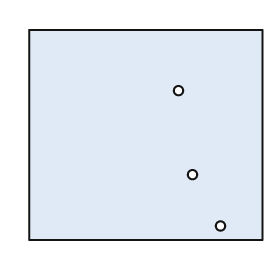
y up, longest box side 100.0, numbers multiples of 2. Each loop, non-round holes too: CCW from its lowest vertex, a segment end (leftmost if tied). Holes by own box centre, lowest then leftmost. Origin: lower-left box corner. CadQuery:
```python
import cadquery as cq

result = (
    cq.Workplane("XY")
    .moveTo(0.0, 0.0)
    .lineTo(100.0, 0.0)
    .lineTo(100.0, 90.0)
    .lineTo(0.0, 90.0)
    .close()
    .moveTo(82.0, 6.0)
    .circle(2.0)
    .moveTo(70.0, 28.0)
    .circle(2.0)
    .moveTo(64.0, 64.0)
    .circle(2.0)
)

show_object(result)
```